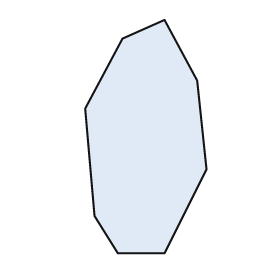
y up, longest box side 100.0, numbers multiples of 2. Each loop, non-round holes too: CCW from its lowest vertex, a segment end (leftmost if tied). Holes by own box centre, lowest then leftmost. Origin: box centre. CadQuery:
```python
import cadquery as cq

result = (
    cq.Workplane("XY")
    .moveTo(-12.0, -50.0)
    .lineTo(8.0, -50.0)
    .lineTo(26.0, -14.0)
    .lineTo(22.0, 24.0)
    .lineTo(8.0, 50.0)
    .lineTo(-10.0, 42.0)
    .lineTo(-26.0, 12.0)
    .lineTo(-22.0, -34.0)
    .close()
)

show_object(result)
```